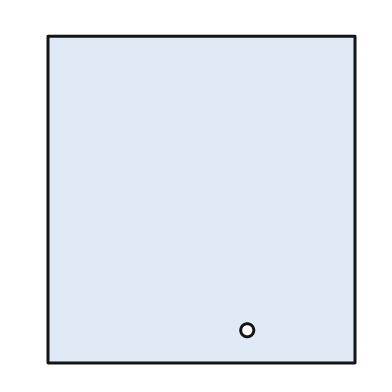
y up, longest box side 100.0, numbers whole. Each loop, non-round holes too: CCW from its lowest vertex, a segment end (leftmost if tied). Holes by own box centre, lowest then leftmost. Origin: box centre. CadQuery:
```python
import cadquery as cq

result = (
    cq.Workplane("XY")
    .moveTo(-47.0, -50.0)
    .lineTo(47.0, -50.0)
    .lineTo(47.0, 50.0)
    .lineTo(-47.0, 50.0)
    .close()
    .moveTo(14.0, -40.0)
    .circle(2.0)
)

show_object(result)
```